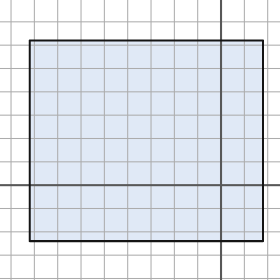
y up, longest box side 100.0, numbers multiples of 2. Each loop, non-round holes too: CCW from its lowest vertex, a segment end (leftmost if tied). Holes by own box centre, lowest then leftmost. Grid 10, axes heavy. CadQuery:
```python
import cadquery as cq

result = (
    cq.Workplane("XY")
    .moveTo(-82.0, -24.0)
    .lineTo(18.0, -24.0)
    .lineTo(18.0, 62.0)
    .lineTo(-82.0, 62.0)
    .close()
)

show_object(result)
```